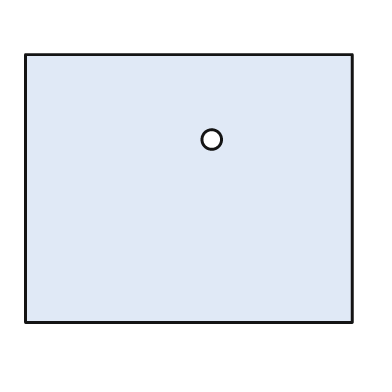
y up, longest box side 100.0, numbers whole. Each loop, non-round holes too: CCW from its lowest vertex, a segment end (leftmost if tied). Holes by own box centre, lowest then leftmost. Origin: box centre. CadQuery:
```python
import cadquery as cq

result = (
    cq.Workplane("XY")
    .moveTo(-50.0, -41.0)
    .lineTo(50.0, -41.0)
    .lineTo(50.0, 41.0)
    .lineTo(-50.0, 41.0)
    .close()
    .moveTo(7.0, 15.0)
    .circle(3.0)
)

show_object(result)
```